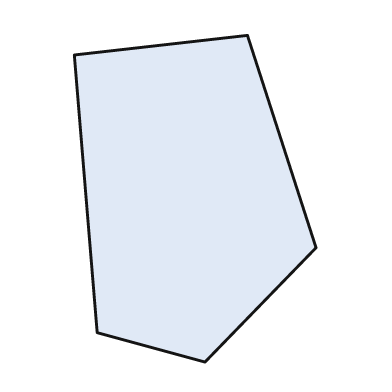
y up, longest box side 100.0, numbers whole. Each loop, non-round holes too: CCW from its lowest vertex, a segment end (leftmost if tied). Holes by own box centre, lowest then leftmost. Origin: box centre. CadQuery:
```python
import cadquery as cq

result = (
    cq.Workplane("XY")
    .moveTo(3.0, -50.0)
    .lineTo(37.0, -15.0)
    .lineTo(16.0, 50.0)
    .lineTo(-37.0, 44.0)
    .lineTo(-30.0, -41.0)
    .close()
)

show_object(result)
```